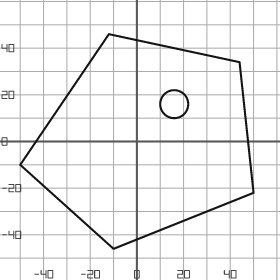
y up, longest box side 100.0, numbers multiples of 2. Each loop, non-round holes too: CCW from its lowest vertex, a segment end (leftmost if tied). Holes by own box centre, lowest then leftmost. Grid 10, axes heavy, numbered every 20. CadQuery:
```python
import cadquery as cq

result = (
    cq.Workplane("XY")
    .moveTo(-10.0, -46.0)
    .lineTo(50.0, -22.0)
    .lineTo(44.0, 34.0)
    .lineTo(-12.0, 46.0)
    .lineTo(-50.0, -10.0)
    .close()
    .moveTo(16.0, 16.0)
    .circle(6.0)
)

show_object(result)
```